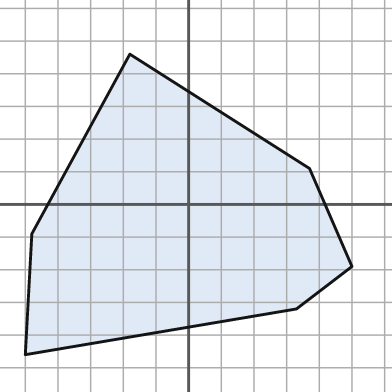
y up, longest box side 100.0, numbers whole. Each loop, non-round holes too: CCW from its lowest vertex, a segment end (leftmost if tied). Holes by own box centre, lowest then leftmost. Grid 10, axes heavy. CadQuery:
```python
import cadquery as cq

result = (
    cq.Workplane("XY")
    .moveTo(-50.0, -46.0)
    .lineTo(33.0, -32.0)
    .lineTo(50.0, -19.0)
    .lineTo(37.0, 11.0)
    .lineTo(-18.0, 46.0)
    .lineTo(-48.0, -9.0)
    .close()
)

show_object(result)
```